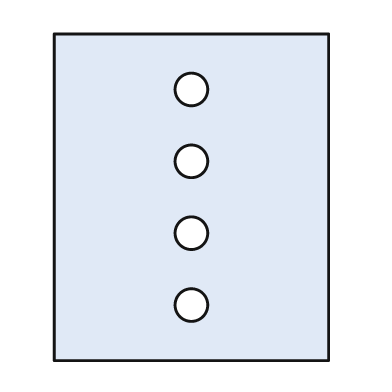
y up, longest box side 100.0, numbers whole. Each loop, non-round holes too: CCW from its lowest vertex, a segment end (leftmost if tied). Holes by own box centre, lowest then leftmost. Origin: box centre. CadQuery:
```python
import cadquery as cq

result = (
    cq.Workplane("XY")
    .moveTo(-42.0, -50.0)
    .lineTo(42.0, -50.0)
    .lineTo(42.0, 50.0)
    .lineTo(-42.0, 50.0)
    .close()
    .moveTo(0.0, -33.0)
    .circle(5.0)
    .moveTo(0.0, -11.0)
    .circle(5.0)
    .moveTo(0.0, 11.0)
    .circle(5.0)
    .moveTo(0.0, 33.0)
    .circle(5.0)
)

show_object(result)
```